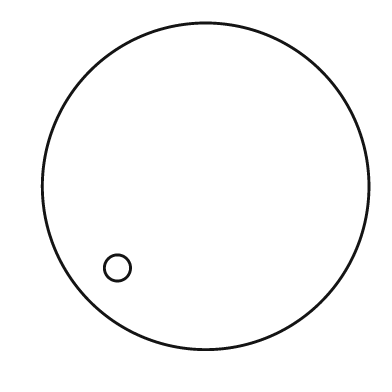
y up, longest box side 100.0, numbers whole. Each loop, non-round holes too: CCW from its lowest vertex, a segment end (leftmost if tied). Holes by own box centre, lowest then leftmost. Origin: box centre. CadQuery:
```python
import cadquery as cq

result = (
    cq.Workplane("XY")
    .moveTo(0.0, 0.0)
    .circle(50.0)
    .moveTo(-27.0, -25.0)
    .circle(4.0)
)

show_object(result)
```